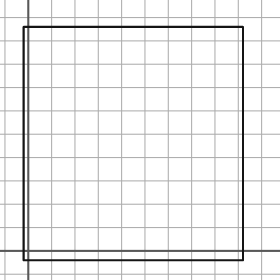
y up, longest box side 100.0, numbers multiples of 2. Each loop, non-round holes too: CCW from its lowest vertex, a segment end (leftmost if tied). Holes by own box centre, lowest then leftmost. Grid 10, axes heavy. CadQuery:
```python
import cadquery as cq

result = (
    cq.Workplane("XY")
    .moveTo(-2.0, -4.0)
    .lineTo(92.0, -4.0)
    .lineTo(92.0, 96.0)
    .lineTo(-2.0, 96.0)
    .close()
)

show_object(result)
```